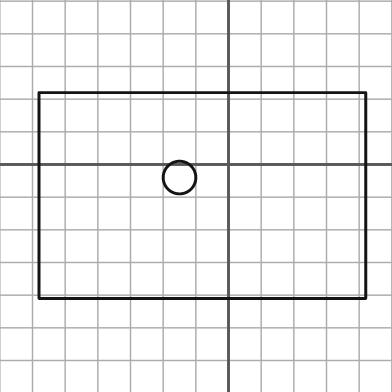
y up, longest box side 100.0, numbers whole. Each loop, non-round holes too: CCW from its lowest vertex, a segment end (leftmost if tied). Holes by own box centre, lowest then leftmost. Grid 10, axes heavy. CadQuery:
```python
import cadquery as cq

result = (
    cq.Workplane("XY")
    .moveTo(-58.0, -41.0)
    .lineTo(42.0, -41.0)
    .lineTo(42.0, 22.0)
    .lineTo(-58.0, 22.0)
    .close()
    .moveTo(-15.0, -4.0)
    .circle(5.0)
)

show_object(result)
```